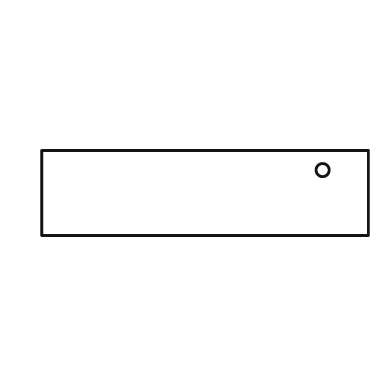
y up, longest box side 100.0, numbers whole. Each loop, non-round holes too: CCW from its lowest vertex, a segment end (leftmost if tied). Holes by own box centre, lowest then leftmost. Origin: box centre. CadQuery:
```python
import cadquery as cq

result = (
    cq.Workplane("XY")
    .moveTo(-50.0, -13.0)
    .lineTo(50.0, -13.0)
    .lineTo(50.0, 13.0)
    .lineTo(-50.0, 13.0)
    .close()
    .moveTo(36.0, 7.0)
    .circle(2.0)
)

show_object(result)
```